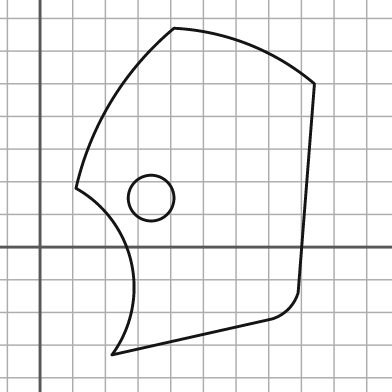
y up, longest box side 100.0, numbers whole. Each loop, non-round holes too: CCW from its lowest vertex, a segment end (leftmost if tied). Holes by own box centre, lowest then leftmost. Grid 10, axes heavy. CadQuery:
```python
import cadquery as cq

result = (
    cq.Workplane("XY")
    .moveTo(22.0, -33.0)
    .lineTo(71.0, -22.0)
    .threePointArc((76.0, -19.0), (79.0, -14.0))
    .lineTo(84.0, 50.0)
    .threePointArc((64.0, 62.0), (41.0, 67.0))
    .threePointArc((22.0, 45.0), (11.0, 18.0))
    .threePointArc((28.0, -5.0), (22.0, -33.0))
    .close()
    .moveTo(34.0, 15.0)
    .circle(7.0)
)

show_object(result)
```